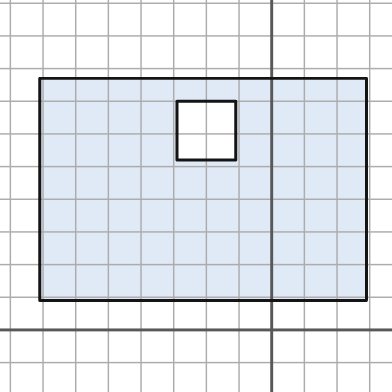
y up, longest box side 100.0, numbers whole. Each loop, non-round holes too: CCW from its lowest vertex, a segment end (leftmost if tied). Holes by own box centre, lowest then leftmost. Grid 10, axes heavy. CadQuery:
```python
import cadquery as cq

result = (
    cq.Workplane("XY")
    .moveTo(-71.0, 9.0)
    .lineTo(29.0, 9.0)
    .lineTo(29.0, 77.0)
    .lineTo(-71.0, 77.0)
    .close()
    .moveTo(-29.0, 52.0)
    .lineTo(-11.0, 52.0)
    .lineTo(-11.0, 70.0)
    .lineTo(-29.0, 70.0)
    .close()
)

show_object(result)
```